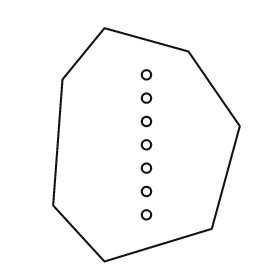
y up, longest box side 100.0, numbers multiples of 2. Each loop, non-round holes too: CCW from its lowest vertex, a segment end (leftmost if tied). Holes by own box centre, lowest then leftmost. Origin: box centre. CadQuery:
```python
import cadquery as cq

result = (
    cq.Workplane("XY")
    .moveTo(-18.0, -50.0)
    .lineTo(28.0, -36.0)
    .lineTo(40.0, 8.0)
    .lineTo(18.0, 40.0)
    .lineTo(-18.0, 50.0)
    .lineTo(-36.0, 28.0)
    .lineTo(-40.0, -26.0)
    .close()
    .moveTo(0.0, -30.0)
    .circle(2.0)
    .moveTo(0.0, -20.0)
    .circle(2.0)
    .moveTo(0.0, -10.0)
    .circle(2.0)
    .moveTo(0.0, 0.0)
    .circle(2.0)
    .moveTo(0.0, 10.0)
    .circle(2.0)
    .moveTo(0.0, 20.0)
    .circle(2.0)
    .moveTo(0.0, 30.0)
    .circle(2.0)
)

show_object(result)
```